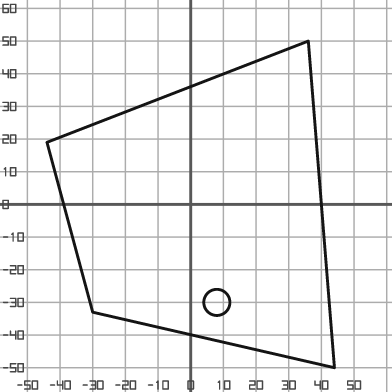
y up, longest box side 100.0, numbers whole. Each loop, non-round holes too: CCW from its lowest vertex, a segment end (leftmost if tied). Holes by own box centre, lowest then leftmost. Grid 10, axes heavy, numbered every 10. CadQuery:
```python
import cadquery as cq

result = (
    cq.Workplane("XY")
    .moveTo(44.0, -50.0)
    .lineTo(36.0, 50.0)
    .lineTo(-44.0, 19.0)
    .lineTo(-30.0, -33.0)
    .close()
    .moveTo(8.0, -30.0)
    .circle(4.0)
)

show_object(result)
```